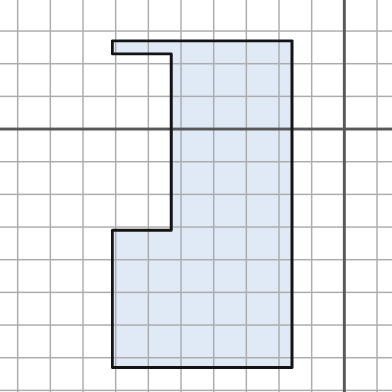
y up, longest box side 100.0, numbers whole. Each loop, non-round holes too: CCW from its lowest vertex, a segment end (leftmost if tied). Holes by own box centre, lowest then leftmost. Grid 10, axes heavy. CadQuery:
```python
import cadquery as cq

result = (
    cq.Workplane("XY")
    .moveTo(-71.0, -73.0)
    .lineTo(-16.0, -73.0)
    .lineTo(-16.0, 27.0)
    .lineTo(-71.0, 27.0)
    .lineTo(-71.0, 23.0)
    .lineTo(-53.0, 23.0)
    .lineTo(-53.0, -31.0)
    .lineTo(-71.0, -31.0)
    .close()
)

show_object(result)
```